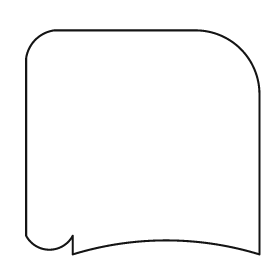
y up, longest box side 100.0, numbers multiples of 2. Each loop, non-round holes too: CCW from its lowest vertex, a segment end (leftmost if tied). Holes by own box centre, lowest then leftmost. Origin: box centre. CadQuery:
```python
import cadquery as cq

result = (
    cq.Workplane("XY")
    .moveTo(-30.0, -48.0)
    .threePointArc((10.0, -42.0), (50.0, -48.0))
    .lineTo(50.0, 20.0)
    .threePointArc((42.0, 40.0), (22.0, 48.0))
    .lineTo(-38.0, 48.0)
    .threePointArc((-46.0, 44.0), (-50.0, 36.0))
    .lineTo(-50.0, -40.0)
    .threePointArc((-40.0, -46.0), (-30.0, -40.0))
    .close()
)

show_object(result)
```